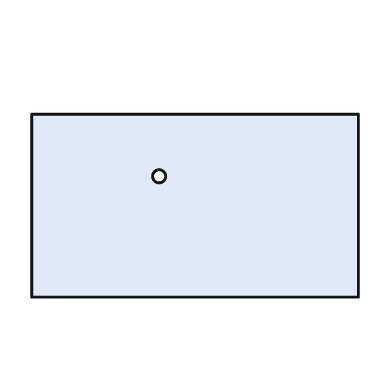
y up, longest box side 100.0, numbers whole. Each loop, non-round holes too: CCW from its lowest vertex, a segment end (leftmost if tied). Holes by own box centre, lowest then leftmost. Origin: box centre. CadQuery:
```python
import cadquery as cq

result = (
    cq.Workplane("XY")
    .moveTo(-50.0, -28.0)
    .lineTo(50.0, -28.0)
    .lineTo(50.0, 28.0)
    .lineTo(-50.0, 28.0)
    .close()
    .moveTo(-11.0, 9.0)
    .circle(2.0)
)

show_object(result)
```